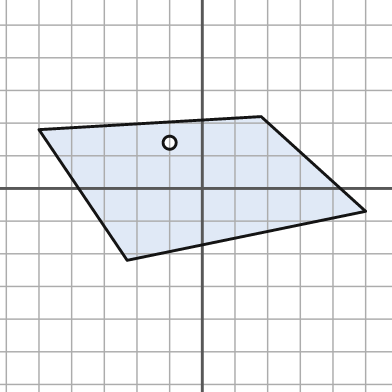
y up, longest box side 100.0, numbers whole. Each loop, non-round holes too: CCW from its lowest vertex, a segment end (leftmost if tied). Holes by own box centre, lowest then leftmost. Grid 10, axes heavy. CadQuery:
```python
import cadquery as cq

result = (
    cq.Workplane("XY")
    .moveTo(-23.0, -22.0)
    .lineTo(50.0, -7.0)
    .lineTo(18.0, 22.0)
    .lineTo(-50.0, 18.0)
    .close()
    .moveTo(-10.0, 14.0)
    .circle(2.0)
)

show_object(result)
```